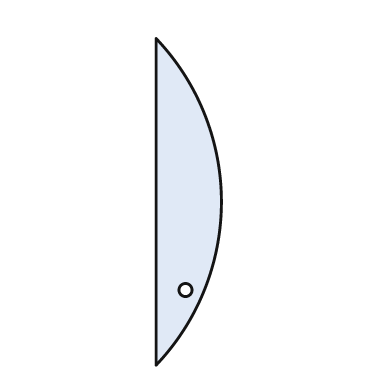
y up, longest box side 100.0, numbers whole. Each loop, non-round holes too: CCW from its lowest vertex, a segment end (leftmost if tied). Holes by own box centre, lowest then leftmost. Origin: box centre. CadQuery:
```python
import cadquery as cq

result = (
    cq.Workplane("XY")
    .moveTo(-10.0, -50.0)
    .threePointArc((10.0, 0.0), (-10.0, 50.0))
    .close()
    .moveTo(-1.0, -27.0)
    .circle(2.0)
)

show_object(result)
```